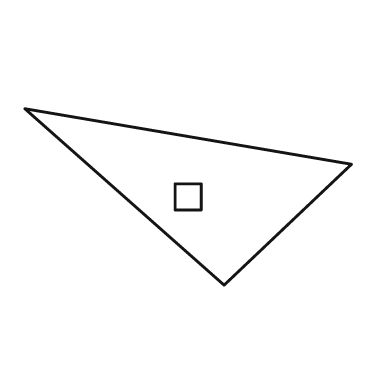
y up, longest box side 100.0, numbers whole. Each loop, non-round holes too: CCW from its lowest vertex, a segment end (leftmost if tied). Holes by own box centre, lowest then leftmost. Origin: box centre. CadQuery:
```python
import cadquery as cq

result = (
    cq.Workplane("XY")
    .moveTo(11.0, -27.0)
    .lineTo(50.0, 10.0)
    .lineTo(-50.0, 27.0)
    .close()
    .moveTo(-4.0, -4.0)
    .lineTo(4.0, -4.0)
    .lineTo(4.0, 4.0)
    .lineTo(-4.0, 4.0)
    .close()
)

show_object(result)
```